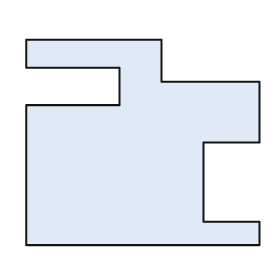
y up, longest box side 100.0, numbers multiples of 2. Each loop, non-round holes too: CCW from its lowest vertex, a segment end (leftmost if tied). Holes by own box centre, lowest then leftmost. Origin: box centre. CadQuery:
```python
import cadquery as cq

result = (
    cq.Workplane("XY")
    .moveTo(-50.0, -44.0)
    .lineTo(50.0, -44.0)
    .lineTo(50.0, -34.0)
    .lineTo(26.0, -34.0)
    .lineTo(26.0, 0.0)
    .lineTo(50.0, 0.0)
    .lineTo(50.0, 26.0)
    .lineTo(8.0, 26.0)
    .lineTo(8.0, 44.0)
    .lineTo(-50.0, 44.0)
    .lineTo(-50.0, 32.0)
    .lineTo(-10.0, 32.0)
    .lineTo(-10.0, 16.0)
    .lineTo(-50.0, 16.0)
    .close()
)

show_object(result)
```